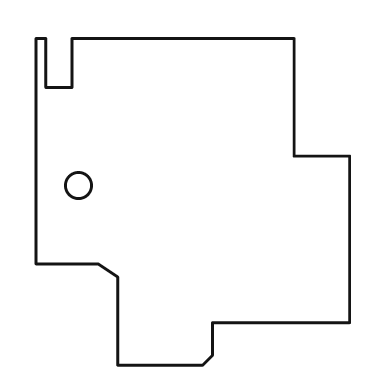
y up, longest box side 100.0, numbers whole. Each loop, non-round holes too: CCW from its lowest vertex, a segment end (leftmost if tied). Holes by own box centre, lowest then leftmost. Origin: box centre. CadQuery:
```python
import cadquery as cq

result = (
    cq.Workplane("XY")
    .moveTo(-23.0, -50.0)
    .lineTo(3.0, -50.0)
    .lineTo(6.0, -47.0)
    .lineTo(6.0, -37.0)
    .lineTo(48.0, -37.0)
    .lineTo(48.0, 14.0)
    .lineTo(31.0, 14.0)
    .lineTo(31.0, 50.0)
    .lineTo(-37.0, 50.0)
    .lineTo(-37.0, 35.0)
    .lineTo(-45.0, 35.0)
    .lineTo(-45.0, 50.0)
    .lineTo(-48.0, 50.0)
    .lineTo(-48.0, -19.0)
    .lineTo(-29.0, -19.0)
    .lineTo(-23.0, -23.0)
    .close()
    .moveTo(-35.0, 5.0)
    .circle(4.0)
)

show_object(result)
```